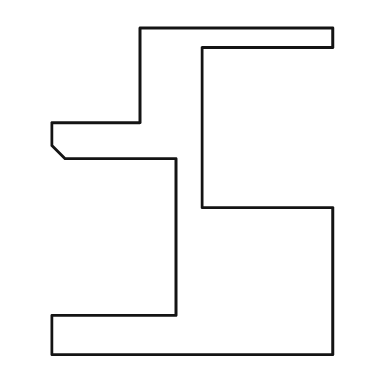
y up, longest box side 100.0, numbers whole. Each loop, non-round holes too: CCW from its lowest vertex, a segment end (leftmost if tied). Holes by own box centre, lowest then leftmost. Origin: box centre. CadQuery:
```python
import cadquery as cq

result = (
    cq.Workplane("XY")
    .moveTo(-43.0, -50.0)
    .lineTo(43.0, -50.0)
    .lineTo(43.0, -5.0)
    .lineTo(3.0, -5.0)
    .lineTo(3.0, 44.0)
    .lineTo(43.0, 44.0)
    .lineTo(43.0, 50.0)
    .lineTo(-16.0, 50.0)
    .lineTo(-16.0, 21.0)
    .lineTo(-43.0, 21.0)
    .lineTo(-43.0, 14.0)
    .lineTo(-39.0, 10.0)
    .lineTo(-5.0, 10.0)
    .lineTo(-5.0, -38.0)
    .lineTo(-43.0, -38.0)
    .close()
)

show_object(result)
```